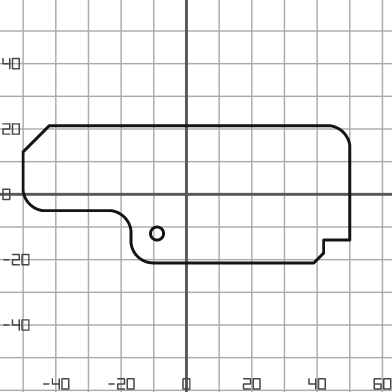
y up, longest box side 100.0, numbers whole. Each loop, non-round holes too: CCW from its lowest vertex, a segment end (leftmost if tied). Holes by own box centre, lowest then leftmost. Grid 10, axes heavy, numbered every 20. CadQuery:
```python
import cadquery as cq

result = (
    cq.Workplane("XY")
    .moveTo(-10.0, -21.0)
    .lineTo(39.0, -21.0)
    .lineTo(42.0, -18.0)
    .lineTo(42.0, -14.0)
    .lineTo(50.0, -14.0)
    .lineTo(50.0, 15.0)
    .threePointArc((48.0, 19.0), (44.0, 21.0))
    .lineTo(-42.0, 21.0)
    .lineTo(-50.0, 13.0)
    .lineTo(-50.0, 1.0)
    .threePointArc((-48.0, -3.0), (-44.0, -5.0))
    .lineTo(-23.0, -5.0)
    .threePointArc((-19.0, -7.0), (-17.0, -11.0))
    .lineTo(-17.0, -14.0)
    .threePointArc((-15.0, -19.0), (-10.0, -21.0))
    .close()
    .moveTo(-9.0, -12.0)
    .circle(2.0)
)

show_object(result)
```